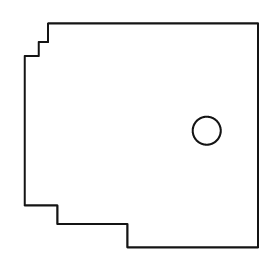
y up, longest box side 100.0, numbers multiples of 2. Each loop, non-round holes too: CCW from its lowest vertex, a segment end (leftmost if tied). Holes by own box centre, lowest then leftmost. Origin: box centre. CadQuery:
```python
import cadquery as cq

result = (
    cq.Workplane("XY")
    .moveTo(-6.0, -48.0)
    .lineTo(50.0, -48.0)
    .lineTo(50.0, 48.0)
    .lineTo(-40.0, 48.0)
    .lineTo(-40.0, 40.0)
    .lineTo(-44.0, 40.0)
    .lineTo(-44.0, 34.0)
    .lineTo(-50.0, 34.0)
    .lineTo(-50.0, -30.0)
    .lineTo(-36.0, -30.0)
    .lineTo(-36.0, -38.0)
    .lineTo(-6.0, -38.0)
    .close()
    .moveTo(28.0, 2.0)
    .circle(6.0)
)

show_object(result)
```